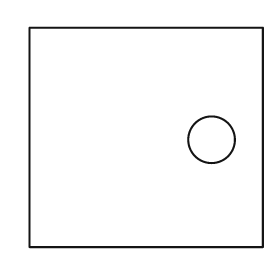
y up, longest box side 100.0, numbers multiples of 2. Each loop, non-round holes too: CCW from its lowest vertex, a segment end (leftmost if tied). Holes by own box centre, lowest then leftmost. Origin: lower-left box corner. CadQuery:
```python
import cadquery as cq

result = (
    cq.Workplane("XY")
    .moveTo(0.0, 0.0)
    .lineTo(100.0, 0.0)
    .lineTo(100.0, 94.0)
    .lineTo(0.0, 94.0)
    .close()
    .moveTo(78.0, 46.0)
    .circle(10.0)
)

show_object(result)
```